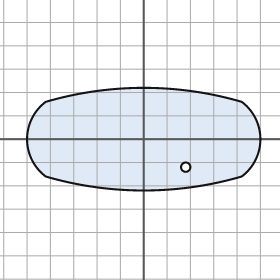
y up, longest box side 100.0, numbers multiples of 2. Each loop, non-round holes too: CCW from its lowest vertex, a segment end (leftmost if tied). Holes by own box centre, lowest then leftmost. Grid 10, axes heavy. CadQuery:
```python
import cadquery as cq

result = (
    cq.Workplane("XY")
    .moveTo(-42.0, -16.0)
    .threePointArc((0.0, -22.0), (42.0, -16.0))
    .threePointArc((50.0, 0.0), (42.0, 16.0))
    .threePointArc((0.0, 22.0), (-42.0, 16.0))
    .threePointArc((-50.0, 0.0), (-42.0, -16.0))
    .close()
    .moveTo(18.0, -12.0)
    .circle(2.0)
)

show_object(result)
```